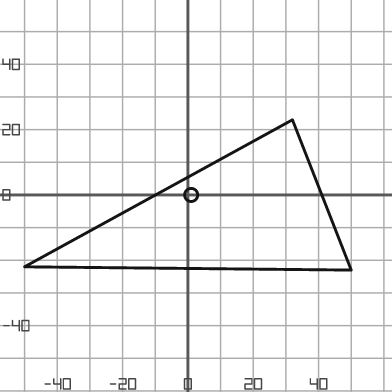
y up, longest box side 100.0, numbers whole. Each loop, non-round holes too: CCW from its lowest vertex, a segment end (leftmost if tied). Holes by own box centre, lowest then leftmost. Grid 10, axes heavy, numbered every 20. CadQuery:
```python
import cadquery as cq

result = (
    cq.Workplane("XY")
    .moveTo(50.0, -23.0)
    .lineTo(32.0, 23.0)
    .lineTo(-50.0, -22.0)
    .close()
    .moveTo(1.0, 0.0)
    .circle(2.0)
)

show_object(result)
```